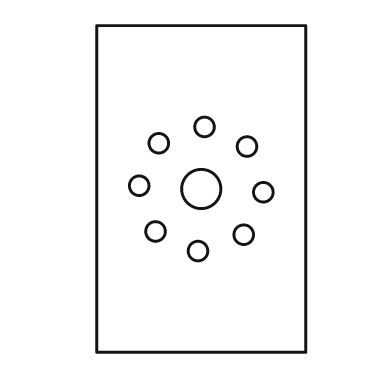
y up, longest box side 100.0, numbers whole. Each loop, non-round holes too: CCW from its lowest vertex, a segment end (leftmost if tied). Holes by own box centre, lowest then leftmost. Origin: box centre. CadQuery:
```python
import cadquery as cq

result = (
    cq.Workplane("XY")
    .moveTo(-32.0, -50.0)
    .lineTo(32.0, -50.0)
    .lineTo(32.0, 50.0)
    .lineTo(-32.0, 50.0)
    .close()
    .moveTo(-1.0, -19.0)
    .circle(3.0)
    .moveTo(13.0, -14.0)
    .circle(3.0)
    .moveTo(-14.0, -13.0)
    .circle(3.0)
    .moveTo(19.0, -1.0)
    .circle(3.0)
    .moveTo(0.0, 0.0)
    .circle(6.0)
    .moveTo(-19.0, 1.0)
    .circle(3.0)
    .moveTo(14.0, 13.0)
    .circle(3.0)
    .moveTo(-13.0, 14.0)
    .circle(3.0)
    .moveTo(1.0, 19.0)
    .circle(3.0)
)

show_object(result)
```